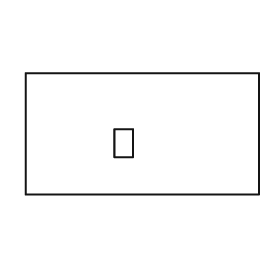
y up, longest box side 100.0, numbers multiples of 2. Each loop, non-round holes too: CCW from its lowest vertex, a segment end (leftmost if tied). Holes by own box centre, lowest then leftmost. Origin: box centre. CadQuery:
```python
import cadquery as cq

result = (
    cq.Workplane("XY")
    .moveTo(-50.0, -26.0)
    .lineTo(50.0, -26.0)
    .lineTo(50.0, 26.0)
    .lineTo(-50.0, 26.0)
    .close()
    .moveTo(-12.0, -10.0)
    .lineTo(-4.0, -10.0)
    .lineTo(-4.0, 2.0)
    .lineTo(-12.0, 2.0)
    .close()
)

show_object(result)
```